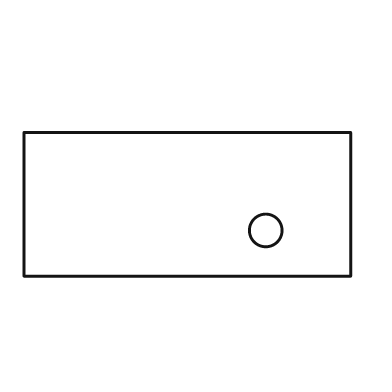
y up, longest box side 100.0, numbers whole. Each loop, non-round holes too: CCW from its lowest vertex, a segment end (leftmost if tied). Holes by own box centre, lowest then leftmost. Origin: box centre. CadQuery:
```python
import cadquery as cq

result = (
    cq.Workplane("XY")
    .moveTo(-50.0, -22.0)
    .lineTo(50.0, -22.0)
    .lineTo(50.0, 22.0)
    .lineTo(-50.0, 22.0)
    .close()
    .moveTo(24.0, -8.0)
    .circle(5.0)
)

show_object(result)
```